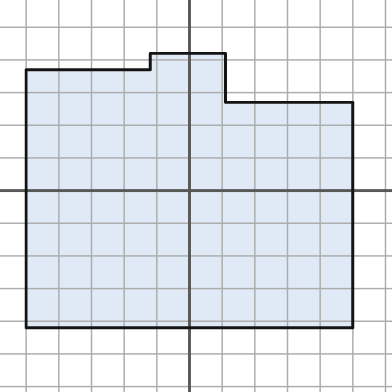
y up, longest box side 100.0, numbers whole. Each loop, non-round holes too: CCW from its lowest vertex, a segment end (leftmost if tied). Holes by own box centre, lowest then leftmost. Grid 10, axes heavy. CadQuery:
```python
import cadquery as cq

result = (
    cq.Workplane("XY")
    .moveTo(-50.0, -42.0)
    .lineTo(50.0, -42.0)
    .lineTo(50.0, 27.0)
    .lineTo(11.0, 27.0)
    .lineTo(11.0, 42.0)
    .lineTo(-12.0, 42.0)
    .lineTo(-12.0, 37.0)
    .lineTo(-50.0, 37.0)
    .close()
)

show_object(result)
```